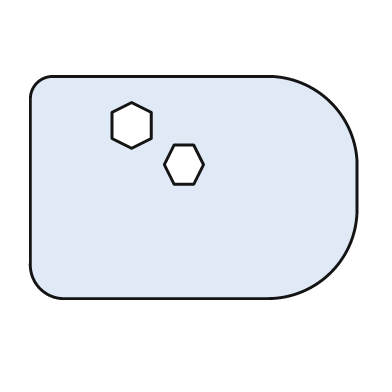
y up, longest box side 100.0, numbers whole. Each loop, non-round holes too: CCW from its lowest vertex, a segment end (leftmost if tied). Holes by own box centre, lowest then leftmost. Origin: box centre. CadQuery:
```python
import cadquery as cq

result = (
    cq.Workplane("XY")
    .moveTo(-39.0, -34.0)
    .lineTo(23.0, -34.0)
    .threePointArc((42.0, -26.0), (50.0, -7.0))
    .lineTo(50.0, 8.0)
    .threePointArc((42.0, 26.0), (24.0, 34.0))
    .lineTo(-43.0, 34.0)
    .threePointArc((-48.0, 32.0), (-50.0, 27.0))
    .lineTo(-50.0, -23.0)
    .threePointArc((-47.0, -31.0), (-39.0, -34.0))
    .close()
    .moveTo(-6.0, 1.0)
    .lineTo(0.0, 1.0)
    .lineTo(3.0, 7.0)
    .lineTo(0.0, 13.0)
    .lineTo(-6.0, 13.0)
    .lineTo(-9.0, 7.0)
    .close()
    .moveTo(-19.0, 12.0)
    .lineTo(-13.0, 15.0)
    .lineTo(-13.0, 23.0)
    .lineTo(-19.0, 26.0)
    .lineTo(-25.0, 23.0)
    .lineTo(-25.0, 15.0)
    .close()
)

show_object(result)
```